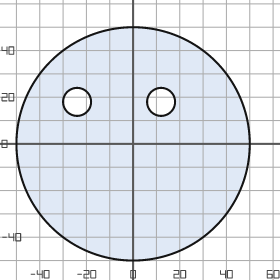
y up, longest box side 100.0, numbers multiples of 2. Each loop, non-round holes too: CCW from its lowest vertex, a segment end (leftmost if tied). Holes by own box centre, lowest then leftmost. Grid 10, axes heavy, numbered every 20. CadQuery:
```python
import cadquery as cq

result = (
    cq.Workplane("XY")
    .moveTo(0.0, 0.0)
    .circle(50.0)
    .moveTo(-24.0, 18.0)
    .circle(6.0)
    .moveTo(12.0, 18.0)
    .circle(6.0)
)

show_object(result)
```